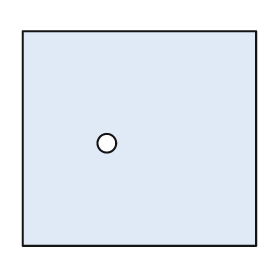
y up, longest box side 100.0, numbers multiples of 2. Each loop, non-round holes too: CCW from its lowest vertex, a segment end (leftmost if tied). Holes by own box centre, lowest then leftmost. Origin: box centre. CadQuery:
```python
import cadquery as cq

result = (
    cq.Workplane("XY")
    .moveTo(-50.0, -46.0)
    .lineTo(50.0, -46.0)
    .lineTo(50.0, 46.0)
    .lineTo(-50.0, 46.0)
    .close()
    .moveTo(-14.0, -2.0)
    .circle(4.0)
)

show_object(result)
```